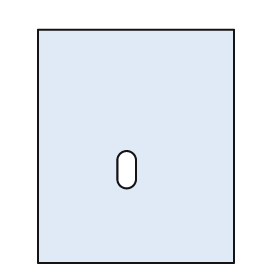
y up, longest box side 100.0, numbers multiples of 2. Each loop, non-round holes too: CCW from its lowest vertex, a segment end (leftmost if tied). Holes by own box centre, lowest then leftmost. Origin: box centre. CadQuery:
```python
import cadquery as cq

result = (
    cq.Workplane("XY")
    .moveTo(-42.0, -50.0)
    .lineTo(42.0, -50.0)
    .lineTo(42.0, 50.0)
    .lineTo(-42.0, 50.0)
    .close()
    .moveTo(-8.0, -14.0)
    .threePointArc((-4.0, -18.0), (0.0, -14.0))
    .lineTo(0.0, -6.0)
    .threePointArc((-4.0, -2.0), (-8.0, -6.0))
    .close()
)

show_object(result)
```